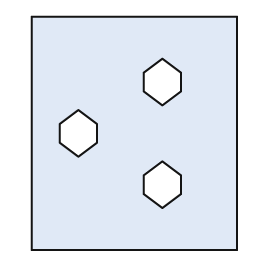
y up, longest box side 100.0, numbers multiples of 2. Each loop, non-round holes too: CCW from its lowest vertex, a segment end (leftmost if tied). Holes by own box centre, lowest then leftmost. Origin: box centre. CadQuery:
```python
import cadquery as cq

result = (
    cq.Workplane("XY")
    .moveTo(-44.0, -50.0)
    .lineTo(44.0, -50.0)
    .lineTo(44.0, 50.0)
    .lineTo(-44.0, 50.0)
    .close()
    .moveTo(12.0, -32.0)
    .lineTo(20.0, -26.0)
    .lineTo(20.0, -18.0)
    .lineTo(12.0, -12.0)
    .lineTo(4.0, -18.0)
    .lineTo(4.0, -26.0)
    .close()
    .moveTo(-24.0, -10.0)
    .lineTo(-16.0, -4.0)
    .lineTo(-16.0, 4.0)
    .lineTo(-24.0, 10.0)
    .lineTo(-32.0, 4.0)
    .lineTo(-32.0, -4.0)
    .close()
    .moveTo(12.0, 12.0)
    .lineTo(20.0, 18.0)
    .lineTo(20.0, 26.0)
    .lineTo(12.0, 32.0)
    .lineTo(4.0, 26.0)
    .lineTo(4.0, 18.0)
    .close()
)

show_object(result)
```